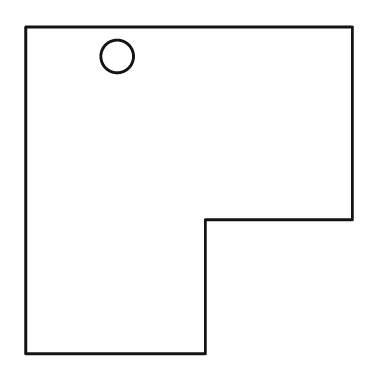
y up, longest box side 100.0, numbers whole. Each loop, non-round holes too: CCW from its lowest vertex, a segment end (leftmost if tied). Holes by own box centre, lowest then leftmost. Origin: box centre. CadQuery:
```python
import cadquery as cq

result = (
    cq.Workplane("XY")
    .moveTo(-50.0, -50.0)
    .lineTo(5.0, -50.0)
    .lineTo(5.0, -9.0)
    .lineTo(50.0, -9.0)
    .lineTo(50.0, 50.0)
    .lineTo(-50.0, 50.0)
    .close()
    .moveTo(-22.0, 41.0)
    .circle(5.0)
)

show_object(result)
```